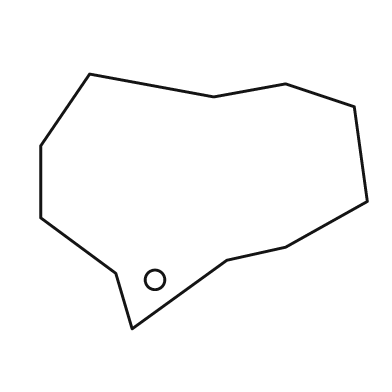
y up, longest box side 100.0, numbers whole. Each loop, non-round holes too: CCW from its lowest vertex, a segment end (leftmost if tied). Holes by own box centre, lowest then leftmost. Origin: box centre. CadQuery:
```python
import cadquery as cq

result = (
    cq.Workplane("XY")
    .moveTo(-22.0, -39.0)
    .lineTo(7.0, -18.0)
    .lineTo(25.0, -14.0)
    .lineTo(50.0, 0.0)
    .lineTo(46.0, 29.0)
    .lineTo(25.0, 36.0)
    .lineTo(3.0, 32.0)
    .lineTo(-35.0, 39.0)
    .lineTo(-50.0, 17.0)
    .lineTo(-50.0, -5.0)
    .lineTo(-27.0, -22.0)
    .close()
    .moveTo(-15.0, -24.0)
    .circle(3.0)
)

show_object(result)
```